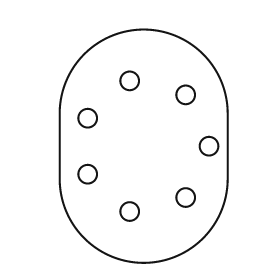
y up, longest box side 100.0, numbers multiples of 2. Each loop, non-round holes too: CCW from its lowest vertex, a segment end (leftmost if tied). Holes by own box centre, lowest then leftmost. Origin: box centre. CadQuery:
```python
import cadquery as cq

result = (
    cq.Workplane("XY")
    .moveTo(-36.0, -14.0)
    .threePointArc((0.0, -50.0), (36.0, -14.0))
    .lineTo(36.0, 14.0)
    .threePointArc((0.0, 50.0), (-36.0, 14.0))
    .close()
    .moveTo(-6.0, -28.0)
    .circle(4.0)
    .moveTo(18.0, -22.0)
    .circle(4.0)
    .moveTo(-24.0, -12.0)
    .circle(4.0)
    .moveTo(28.0, 0.0)
    .circle(4.0)
    .moveTo(-24.0, 12.0)
    .circle(4.0)
    .moveTo(18.0, 22.0)
    .circle(4.0)
    .moveTo(-6.0, 28.0)
    .circle(4.0)
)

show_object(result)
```